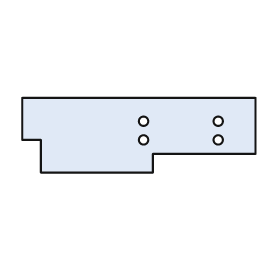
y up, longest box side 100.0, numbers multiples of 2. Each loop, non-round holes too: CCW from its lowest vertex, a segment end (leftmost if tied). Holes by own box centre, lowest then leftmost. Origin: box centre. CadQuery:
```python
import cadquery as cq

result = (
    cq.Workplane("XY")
    .moveTo(-42.0, -16.0)
    .lineTo(6.0, -16.0)
    .lineTo(6.0, -8.0)
    .lineTo(50.0, -8.0)
    .lineTo(50.0, 16.0)
    .lineTo(-50.0, 16.0)
    .lineTo(-50.0, -2.0)
    .lineTo(-42.0, -2.0)
    .close()
    .moveTo(2.0, -2.0)
    .circle(2.0)
    .moveTo(34.0, -2.0)
    .circle(2.0)
    .moveTo(2.0, 6.0)
    .circle(2.0)
    .moveTo(34.0, 6.0)
    .circle(2.0)
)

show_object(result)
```